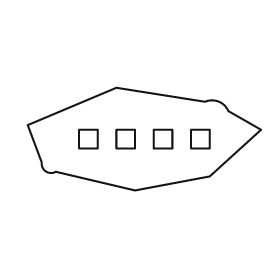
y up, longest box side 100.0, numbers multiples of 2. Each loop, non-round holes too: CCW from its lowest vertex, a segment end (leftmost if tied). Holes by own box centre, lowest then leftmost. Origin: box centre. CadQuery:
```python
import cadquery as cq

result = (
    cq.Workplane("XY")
    .moveTo(-4.0, -22.0)
    .lineTo(28.0, -16.0)
    .lineTo(50.0, 4.0)
    .lineTo(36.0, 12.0)
    .threePointArc((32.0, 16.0), (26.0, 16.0))
    .lineTo(-12.0, 22.0)
    .lineTo(-50.0, 6.0)
    .lineTo(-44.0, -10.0)
    .threePointArc((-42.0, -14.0), (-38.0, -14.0))
    .close()
    .moveTo(-28.0, -4.0)
    .lineTo(-20.0, -4.0)
    .lineTo(-20.0, 4.0)
    .lineTo(-28.0, 4.0)
    .close()
    .moveTo(-12.0, -4.0)
    .lineTo(-4.0, -4.0)
    .lineTo(-4.0, 4.0)
    .lineTo(-12.0, 4.0)
    .close()
    .moveTo(4.0, -4.0)
    .lineTo(12.0, -4.0)
    .lineTo(12.0, 4.0)
    .lineTo(4.0, 4.0)
    .close()
    .moveTo(20.0, -4.0)
    .lineTo(28.0, -4.0)
    .lineTo(28.0, 4.0)
    .lineTo(20.0, 4.0)
    .close()
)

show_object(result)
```